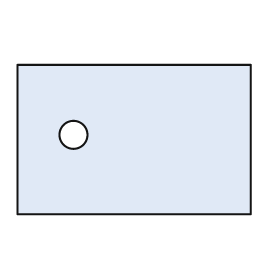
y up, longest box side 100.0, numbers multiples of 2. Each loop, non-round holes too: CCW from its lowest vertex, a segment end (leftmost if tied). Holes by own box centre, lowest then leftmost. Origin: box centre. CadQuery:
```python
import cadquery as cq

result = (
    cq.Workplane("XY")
    .moveTo(-50.0, -32.0)
    .lineTo(50.0, -32.0)
    .lineTo(50.0, 32.0)
    .lineTo(-50.0, 32.0)
    .close()
    .moveTo(-26.0, 2.0)
    .circle(6.0)
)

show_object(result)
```